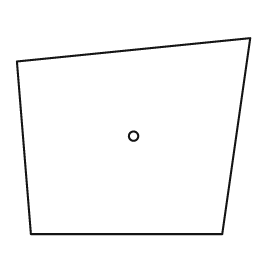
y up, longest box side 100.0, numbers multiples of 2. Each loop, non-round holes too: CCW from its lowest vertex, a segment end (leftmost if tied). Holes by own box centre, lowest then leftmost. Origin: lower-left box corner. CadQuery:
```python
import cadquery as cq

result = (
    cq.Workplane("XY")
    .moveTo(6.0, 0.0)
    .lineTo(88.0, 0.0)
    .lineTo(100.0, 84.0)
    .lineTo(0.0, 74.0)
    .close()
    .moveTo(50.0, 42.0)
    .circle(2.0)
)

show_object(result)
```